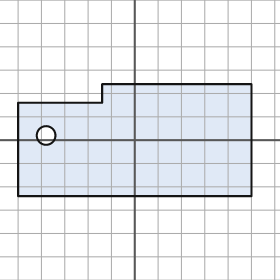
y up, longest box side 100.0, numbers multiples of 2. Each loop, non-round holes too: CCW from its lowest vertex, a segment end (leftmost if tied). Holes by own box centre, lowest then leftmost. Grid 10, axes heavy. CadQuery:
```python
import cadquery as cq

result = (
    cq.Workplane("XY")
    .moveTo(-50.0, -24.0)
    .lineTo(50.0, -24.0)
    .lineTo(50.0, 24.0)
    .lineTo(-14.0, 24.0)
    .lineTo(-14.0, 16.0)
    .lineTo(-50.0, 16.0)
    .close()
    .moveTo(-38.0, 2.0)
    .circle(4.0)
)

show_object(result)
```